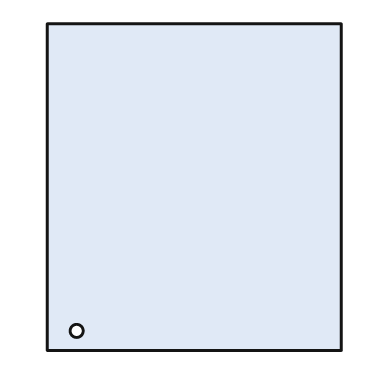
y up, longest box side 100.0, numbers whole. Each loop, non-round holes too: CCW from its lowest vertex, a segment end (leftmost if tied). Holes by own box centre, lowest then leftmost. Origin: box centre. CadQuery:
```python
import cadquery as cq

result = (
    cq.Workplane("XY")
    .moveTo(-45.0, -50.0)
    .lineTo(45.0, -50.0)
    .lineTo(45.0, 50.0)
    .lineTo(-45.0, 50.0)
    .close()
    .moveTo(-36.0, -44.0)
    .circle(2.0)
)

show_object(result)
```